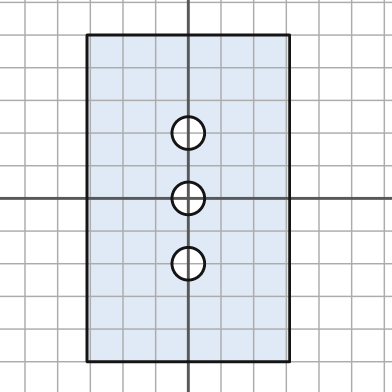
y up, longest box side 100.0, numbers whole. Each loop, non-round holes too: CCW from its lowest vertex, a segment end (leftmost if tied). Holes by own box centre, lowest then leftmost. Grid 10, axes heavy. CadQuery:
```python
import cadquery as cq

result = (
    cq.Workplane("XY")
    .moveTo(-31.0, -50.0)
    .lineTo(31.0, -50.0)
    .lineTo(31.0, 50.0)
    .lineTo(-31.0, 50.0)
    .close()
    .moveTo(0.0, -20.0)
    .circle(5.0)
    .moveTo(0.0, 0.0)
    .circle(5.0)
    .moveTo(0.0, 20.0)
    .circle(5.0)
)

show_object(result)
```